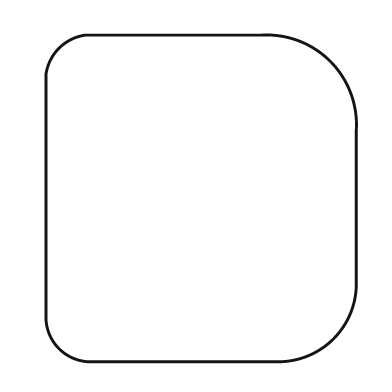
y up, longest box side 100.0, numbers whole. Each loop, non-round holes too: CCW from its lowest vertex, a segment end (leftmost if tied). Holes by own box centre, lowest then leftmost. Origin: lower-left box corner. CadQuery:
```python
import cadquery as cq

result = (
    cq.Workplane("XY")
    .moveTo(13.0, 0.0)
    .lineTo(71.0, 0.0)
    .threePointArc((88.0, 7.0), (95.0, 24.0))
    .lineTo(95.0, 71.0)
    .threePointArc((87.0, 92.0), (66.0, 100.0))
    .lineTo(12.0, 100.0)
    .threePointArc((4.0, 96.0), (0.0, 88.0))
    .lineTo(0.0, 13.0)
    .threePointArc((4.0, 4.0), (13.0, 0.0))
    .close()
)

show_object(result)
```